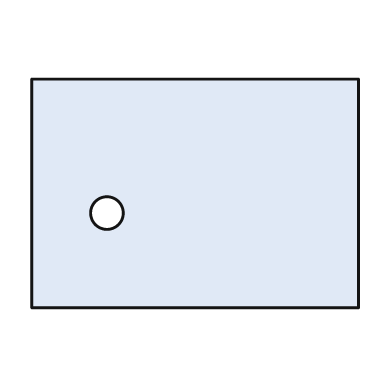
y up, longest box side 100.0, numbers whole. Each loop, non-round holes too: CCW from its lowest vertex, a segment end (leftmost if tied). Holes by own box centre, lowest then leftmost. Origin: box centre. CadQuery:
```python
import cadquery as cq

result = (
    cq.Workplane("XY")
    .moveTo(-50.0, -35.0)
    .lineTo(50.0, -35.0)
    .lineTo(50.0, 35.0)
    .lineTo(-50.0, 35.0)
    .close()
    .moveTo(-27.0, -6.0)
    .circle(5.0)
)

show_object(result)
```